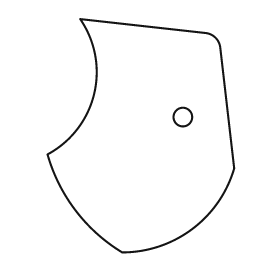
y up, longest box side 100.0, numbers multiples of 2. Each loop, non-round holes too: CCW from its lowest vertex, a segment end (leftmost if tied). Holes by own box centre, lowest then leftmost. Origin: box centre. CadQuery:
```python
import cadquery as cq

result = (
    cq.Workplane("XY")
    .moveTo(-8.0, -50.0)
    .threePointArc((22.0, -40.0), (40.0, -14.0))
    .lineTo(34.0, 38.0)
    .threePointArc((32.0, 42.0), (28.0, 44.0))
    .lineTo(-26.0, 50.0)
    .threePointArc((-20.0, 18.0), (-40.0, -8.0))
    .threePointArc((-28.0, -32.0), (-8.0, -50.0))
    .close()
    .moveTo(18.0, 8.0)
    .circle(4.0)
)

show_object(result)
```